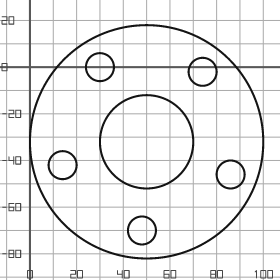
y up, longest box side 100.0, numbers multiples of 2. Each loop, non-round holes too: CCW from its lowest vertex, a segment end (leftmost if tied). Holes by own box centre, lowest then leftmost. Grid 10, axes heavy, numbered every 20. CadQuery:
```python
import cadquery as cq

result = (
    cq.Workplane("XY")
    .moveTo(50.0, -32.0)
    .circle(50.0)
    .moveTo(48.0, -70.0)
    .circle(6.0)
    .moveTo(86.0, -46.0)
    .circle(6.0)
    .moveTo(14.0, -42.0)
    .circle(6.0)
    .moveTo(50.0, -32.0)
    .circle(20.0)
    .moveTo(74.0, -2.0)
    .circle(6.0)
    .moveTo(30.0, 0.0)
    .circle(6.0)
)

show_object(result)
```